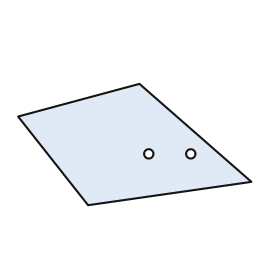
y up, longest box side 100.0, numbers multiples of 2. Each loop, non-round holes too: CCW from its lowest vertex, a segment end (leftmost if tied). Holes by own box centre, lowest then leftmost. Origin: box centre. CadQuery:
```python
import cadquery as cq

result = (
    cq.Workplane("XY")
    .moveTo(-20.0, -26.0)
    .lineTo(50.0, -16.0)
    .lineTo(2.0, 26.0)
    .lineTo(-50.0, 12.0)
    .close()
    .moveTo(6.0, -4.0)
    .circle(2.0)
    .moveTo(24.0, -4.0)
    .circle(2.0)
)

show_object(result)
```